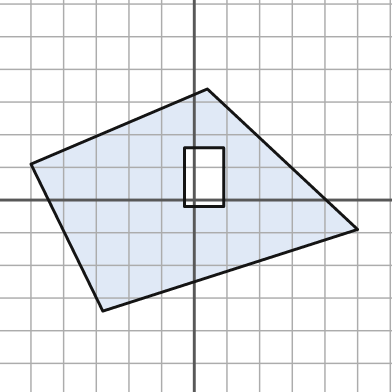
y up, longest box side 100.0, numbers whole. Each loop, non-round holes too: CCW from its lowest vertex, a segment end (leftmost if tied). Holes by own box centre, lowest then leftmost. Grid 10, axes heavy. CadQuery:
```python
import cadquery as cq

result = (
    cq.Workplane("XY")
    .moveTo(-28.0, -34.0)
    .lineTo(50.0, -9.0)
    .lineTo(4.0, 34.0)
    .lineTo(-50.0, 11.0)
    .close()
    .moveTo(-3.0, -2.0)
    .lineTo(9.0, -2.0)
    .lineTo(9.0, 16.0)
    .lineTo(-3.0, 16.0)
    .close()
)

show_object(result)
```